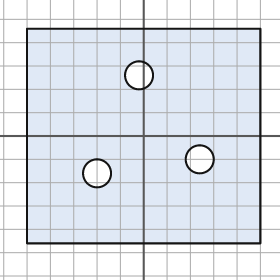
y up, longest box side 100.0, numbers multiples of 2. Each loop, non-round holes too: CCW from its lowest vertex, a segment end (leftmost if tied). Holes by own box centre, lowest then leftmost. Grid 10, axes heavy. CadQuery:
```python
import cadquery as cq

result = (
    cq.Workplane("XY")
    .moveTo(-50.0, -46.0)
    .lineTo(50.0, -46.0)
    .lineTo(50.0, 46.0)
    .lineTo(-50.0, 46.0)
    .close()
    .moveTo(-20.0, -16.0)
    .circle(6.0)
    .moveTo(24.0, -10.0)
    .circle(6.0)
    .moveTo(-2.0, 26.0)
    .circle(6.0)
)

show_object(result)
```